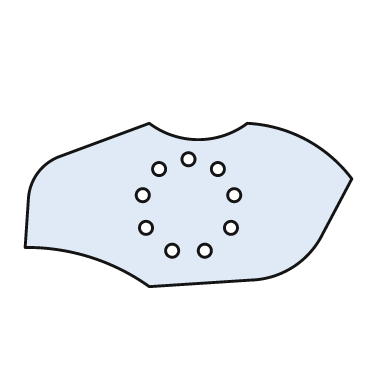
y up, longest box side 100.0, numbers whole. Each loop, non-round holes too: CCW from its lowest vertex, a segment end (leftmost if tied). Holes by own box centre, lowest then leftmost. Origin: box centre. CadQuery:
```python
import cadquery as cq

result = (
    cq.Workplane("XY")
    .moveTo(-12.0, -25.0)
    .lineTo(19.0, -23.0)
    .threePointArc((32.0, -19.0), (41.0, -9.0))
    .lineTo(50.0, 8.0)
    .threePointArc((36.0, 20.0), (18.0, 25.0))
    .threePointArc((3.0, 20.0), (-12.0, 25.0))
    .lineTo(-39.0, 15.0)
    .threePointArc((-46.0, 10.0), (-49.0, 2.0))
    .lineTo(-50.0, -13.0)
    .threePointArc((-30.0, -16.0), (-12.0, -25.0))
    .close()
    .moveTo(-5.0, -14.0)
    .circle(2.0)
    .moveTo(5.0, -14.0)
    .circle(2.0)
    .moveTo(-13.0, -7.0)
    .circle(2.0)
    .moveTo(13.0, -7.0)
    .circle(2.0)
    .moveTo(-14.0, 3.0)
    .circle(2.0)
    .moveTo(14.0, 3.0)
    .circle(2.0)
    .moveTo(-9.0, 11.0)
    .circle(2.0)
    .moveTo(9.0, 11.0)
    .circle(2.0)
    .moveTo(0.0, 14.0)
    .circle(2.0)
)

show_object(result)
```